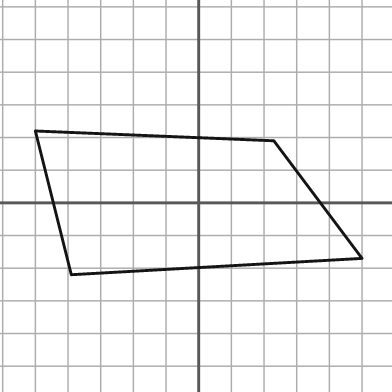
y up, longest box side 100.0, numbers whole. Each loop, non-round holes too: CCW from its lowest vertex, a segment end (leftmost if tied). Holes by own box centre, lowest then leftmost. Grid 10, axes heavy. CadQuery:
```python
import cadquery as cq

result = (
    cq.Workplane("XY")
    .moveTo(-39.0, -22.0)
    .lineTo(50.0, -17.0)
    .lineTo(23.0, 19.0)
    .lineTo(-50.0, 22.0)
    .close()
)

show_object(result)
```